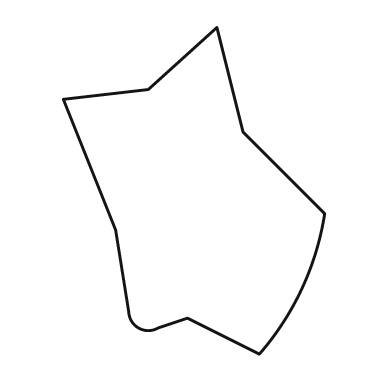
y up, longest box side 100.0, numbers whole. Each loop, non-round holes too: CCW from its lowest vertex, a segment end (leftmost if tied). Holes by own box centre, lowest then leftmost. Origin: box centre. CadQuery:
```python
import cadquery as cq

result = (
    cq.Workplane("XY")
    .moveTo(20.0, -50.0)
    .threePointArc((33.0, -30.0), (40.0, -7.0))
    .lineTo(15.0, 18.0)
    .lineTo(7.0, 50.0)
    .lineTo(-14.0, 31.0)
    .lineTo(-40.0, 28.0)
    .lineTo(-24.0, -12.0)
    .lineTo(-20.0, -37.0)
    .threePointArc((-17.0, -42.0), (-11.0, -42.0))
    .lineTo(-2.0, -39.0)
    .close()
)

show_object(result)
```